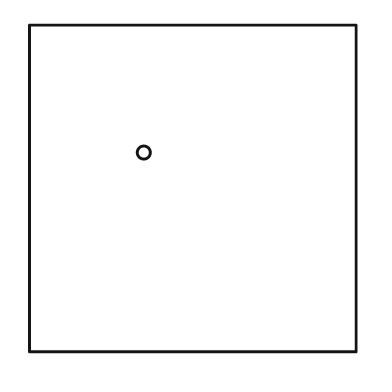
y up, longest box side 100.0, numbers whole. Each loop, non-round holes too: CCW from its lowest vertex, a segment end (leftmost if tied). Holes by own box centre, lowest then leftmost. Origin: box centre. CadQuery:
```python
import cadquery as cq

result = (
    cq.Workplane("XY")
    .moveTo(-50.0, -50.0)
    .lineTo(50.0, -50.0)
    .lineTo(50.0, 50.0)
    .lineTo(-50.0, 50.0)
    .close()
    .moveTo(-15.0, 11.0)
    .circle(2.0)
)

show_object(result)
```